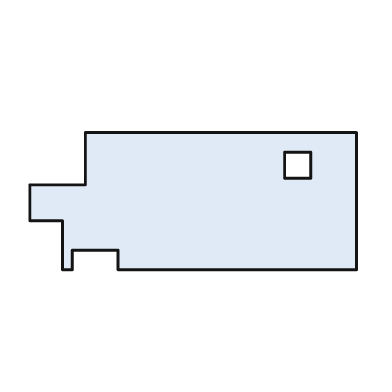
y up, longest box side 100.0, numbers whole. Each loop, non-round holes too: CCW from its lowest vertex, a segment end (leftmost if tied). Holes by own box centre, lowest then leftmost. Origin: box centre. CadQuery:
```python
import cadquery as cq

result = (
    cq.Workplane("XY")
    .moveTo(-40.0, -21.0)
    .lineTo(-37.0, -21.0)
    .lineTo(-37.0, -15.0)
    .lineTo(-23.0, -15.0)
    .lineTo(-23.0, -21.0)
    .lineTo(50.0, -21.0)
    .lineTo(50.0, 21.0)
    .lineTo(-33.0, 21.0)
    .lineTo(-33.0, 5.0)
    .lineTo(-50.0, 5.0)
    .lineTo(-50.0, -6.0)
    .lineTo(-40.0, -6.0)
    .close()
    .moveTo(28.0, 7.0)
    .lineTo(36.0, 7.0)
    .lineTo(36.0, 15.0)
    .lineTo(28.0, 15.0)
    .close()
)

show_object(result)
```